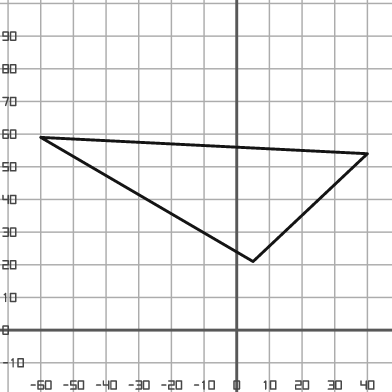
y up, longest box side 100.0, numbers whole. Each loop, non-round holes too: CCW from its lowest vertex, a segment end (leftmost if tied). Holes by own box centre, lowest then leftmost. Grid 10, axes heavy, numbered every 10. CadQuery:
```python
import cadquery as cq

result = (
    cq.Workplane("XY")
    .moveTo(5.0, 21.0)
    .lineTo(40.0, 54.0)
    .lineTo(-60.0, 59.0)
    .close()
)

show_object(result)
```